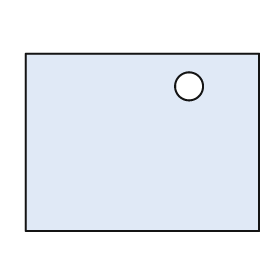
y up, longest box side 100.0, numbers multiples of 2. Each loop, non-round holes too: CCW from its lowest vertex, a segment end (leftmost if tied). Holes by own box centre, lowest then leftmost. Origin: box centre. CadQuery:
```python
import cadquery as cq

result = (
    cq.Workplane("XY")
    .moveTo(-50.0, -38.0)
    .lineTo(50.0, -38.0)
    .lineTo(50.0, 38.0)
    .lineTo(-50.0, 38.0)
    .close()
    .moveTo(20.0, 24.0)
    .circle(6.0)
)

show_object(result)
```